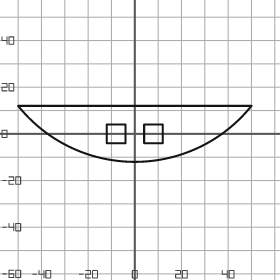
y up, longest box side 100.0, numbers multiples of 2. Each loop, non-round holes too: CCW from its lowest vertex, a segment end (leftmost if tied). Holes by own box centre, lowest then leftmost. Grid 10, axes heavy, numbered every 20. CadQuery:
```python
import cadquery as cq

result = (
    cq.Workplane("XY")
    .moveTo(-50.0, 12.0)
    .threePointArc((0.0, -12.0), (50.0, 12.0))
    .close()
    .moveTo(-12.0, -4.0)
    .lineTo(-4.0, -4.0)
    .lineTo(-4.0, 4.0)
    .lineTo(-12.0, 4.0)
    .close()
    .moveTo(4.0, -4.0)
    .lineTo(12.0, -4.0)
    .lineTo(12.0, 4.0)
    .lineTo(4.0, 4.0)
    .close()
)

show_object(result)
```